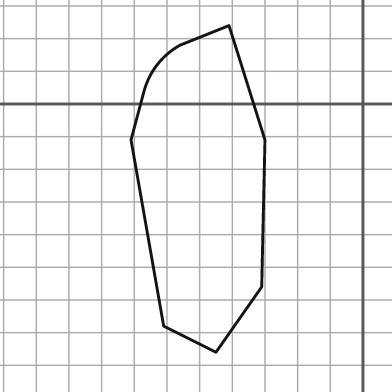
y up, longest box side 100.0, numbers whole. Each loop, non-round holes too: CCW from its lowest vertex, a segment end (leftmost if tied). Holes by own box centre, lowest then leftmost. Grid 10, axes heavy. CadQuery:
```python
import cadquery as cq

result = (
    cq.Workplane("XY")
    .moveTo(-45.0, -76.0)
    .lineTo(-31.0, -56.0)
    .lineTo(-30.0, -11.0)
    .lineTo(-41.0, 24.0)
    .lineTo(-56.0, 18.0)
    .threePointArc((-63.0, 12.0), (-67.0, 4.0))
    .lineTo(-71.0, -11.0)
    .lineTo(-61.0, -68.0)
    .close()
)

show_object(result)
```